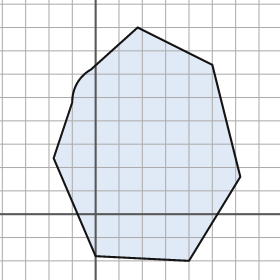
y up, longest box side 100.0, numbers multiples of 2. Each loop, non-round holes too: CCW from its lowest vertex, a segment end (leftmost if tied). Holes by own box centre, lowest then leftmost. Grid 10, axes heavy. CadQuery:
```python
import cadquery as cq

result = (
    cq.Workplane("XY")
    .moveTo(40.0, -20.0)
    .lineTo(62.0, 16.0)
    .lineTo(50.0, 64.0)
    .lineTo(18.0, 80.0)
    .lineTo(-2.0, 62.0)
    .threePointArc((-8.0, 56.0), (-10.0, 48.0))
    .lineTo(-18.0, 24.0)
    .lineTo(0.0, -18.0)
    .close()
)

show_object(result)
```